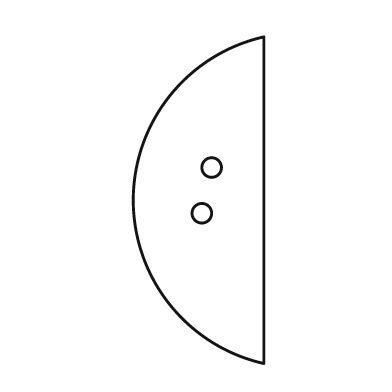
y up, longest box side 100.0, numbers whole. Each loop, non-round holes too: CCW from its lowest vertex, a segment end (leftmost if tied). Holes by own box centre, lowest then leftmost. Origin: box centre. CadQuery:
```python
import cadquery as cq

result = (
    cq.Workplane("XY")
    .moveTo(20.0, -50.0)
    .lineTo(20.0, 50.0)
    .threePointArc((-20.0, 0.0), (20.0, -50.0))
    .close()
    .moveTo(1.0, -4.0)
    .circle(3.0)
    .moveTo(4.0, 10.0)
    .circle(3.0)
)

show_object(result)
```